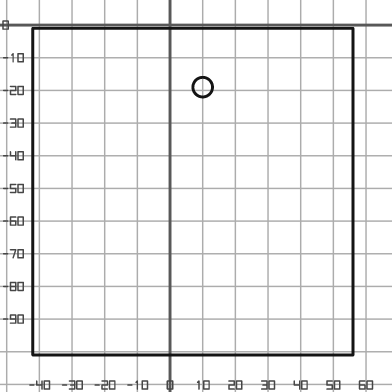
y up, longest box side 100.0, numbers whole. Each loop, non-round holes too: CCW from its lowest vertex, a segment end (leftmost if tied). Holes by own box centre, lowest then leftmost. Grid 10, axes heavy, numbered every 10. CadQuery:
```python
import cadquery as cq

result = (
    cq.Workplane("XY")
    .moveTo(-42.0, -101.0)
    .lineTo(56.0, -101.0)
    .lineTo(56.0, -1.0)
    .lineTo(-42.0, -1.0)
    .close()
    .moveTo(10.0, -19.0)
    .circle(3.0)
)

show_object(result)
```